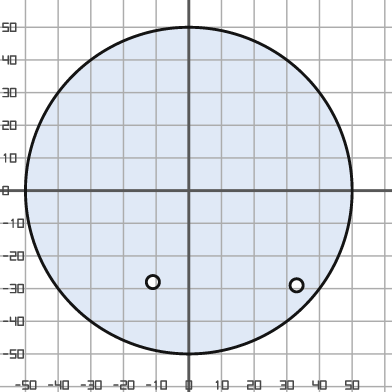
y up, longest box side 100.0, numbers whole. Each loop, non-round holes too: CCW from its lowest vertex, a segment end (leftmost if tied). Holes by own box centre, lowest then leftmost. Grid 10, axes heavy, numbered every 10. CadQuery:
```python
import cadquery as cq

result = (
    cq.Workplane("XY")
    .moveTo(0.0, 0.0)
    .circle(50.0)
    .moveTo(33.0, -29.0)
    .circle(2.0)
    .moveTo(-11.0, -28.0)
    .circle(2.0)
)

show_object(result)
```